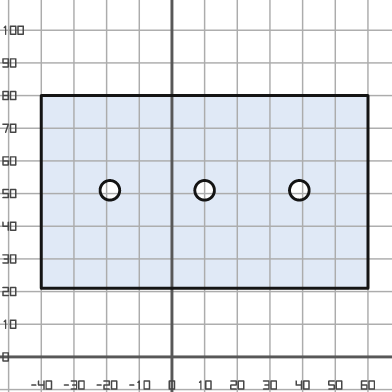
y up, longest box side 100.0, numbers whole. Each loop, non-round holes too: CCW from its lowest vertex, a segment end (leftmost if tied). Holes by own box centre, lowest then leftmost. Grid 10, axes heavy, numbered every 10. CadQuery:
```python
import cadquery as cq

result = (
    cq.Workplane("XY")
    .moveTo(-40.0, 21.0)
    .lineTo(60.0, 21.0)
    .lineTo(60.0, 80.0)
    .lineTo(-40.0, 80.0)
    .close()
    .moveTo(-19.0, 51.0)
    .circle(3.0)
    .moveTo(10.0, 51.0)
    .circle(3.0)
    .moveTo(39.0, 51.0)
    .circle(3.0)
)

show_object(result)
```